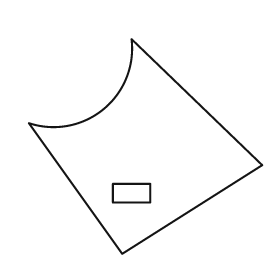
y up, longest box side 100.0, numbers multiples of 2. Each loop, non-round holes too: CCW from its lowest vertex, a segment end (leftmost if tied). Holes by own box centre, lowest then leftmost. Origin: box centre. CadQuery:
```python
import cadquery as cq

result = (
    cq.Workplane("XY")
    .moveTo(-10.0, -46.0)
    .lineTo(50.0, -8.0)
    .lineTo(-6.0, 46.0)
    .threePointArc((-18.0, 16.0), (-50.0, 10.0))
    .close()
    .moveTo(-14.0, -24.0)
    .lineTo(2.0, -24.0)
    .lineTo(2.0, -16.0)
    .lineTo(-14.0, -16.0)
    .close()
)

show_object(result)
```